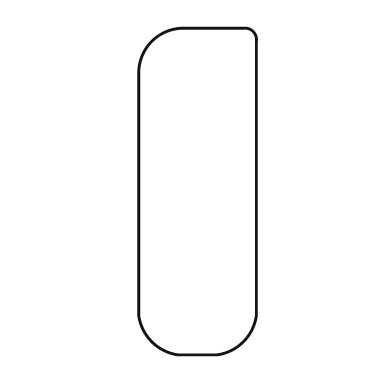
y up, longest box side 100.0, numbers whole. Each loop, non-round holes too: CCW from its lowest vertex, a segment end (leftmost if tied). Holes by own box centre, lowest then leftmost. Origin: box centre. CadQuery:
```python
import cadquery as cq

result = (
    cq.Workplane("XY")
    .moveTo(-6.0, -50.0)
    .lineTo(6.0, -50.0)
    .threePointArc((14.0, -46.0), (18.0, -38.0))
    .lineTo(18.0, 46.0)
    .threePointArc((17.0, 49.0), (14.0, 50.0))
    .lineTo(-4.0, 50.0)
    .threePointArc((-14.0, 46.0), (-18.0, 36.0))
    .lineTo(-18.0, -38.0)
    .threePointArc((-14.0, -46.0), (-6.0, -50.0))
    .close()
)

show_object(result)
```